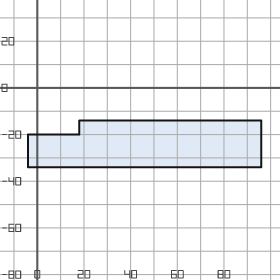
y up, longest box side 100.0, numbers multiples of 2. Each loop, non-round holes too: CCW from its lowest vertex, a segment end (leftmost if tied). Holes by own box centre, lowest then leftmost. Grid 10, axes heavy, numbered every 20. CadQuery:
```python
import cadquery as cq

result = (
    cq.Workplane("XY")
    .moveTo(-4.0, -34.0)
    .lineTo(96.0, -34.0)
    .lineTo(96.0, -14.0)
    .lineTo(18.0, -14.0)
    .lineTo(18.0, -20.0)
    .lineTo(-4.0, -20.0)
    .close()
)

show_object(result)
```